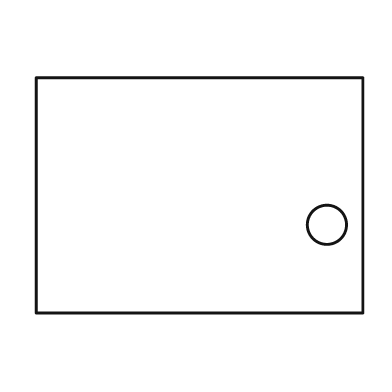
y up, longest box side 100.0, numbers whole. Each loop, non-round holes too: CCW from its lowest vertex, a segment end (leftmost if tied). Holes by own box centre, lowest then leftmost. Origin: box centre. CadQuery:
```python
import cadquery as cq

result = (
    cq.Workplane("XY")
    .moveTo(-50.0, -36.0)
    .lineTo(50.0, -36.0)
    .lineTo(50.0, 36.0)
    .lineTo(-50.0, 36.0)
    .close()
    .moveTo(39.0, -9.0)
    .circle(6.0)
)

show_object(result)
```